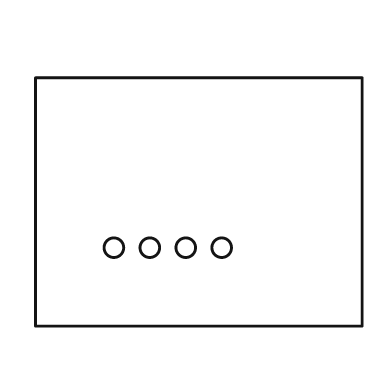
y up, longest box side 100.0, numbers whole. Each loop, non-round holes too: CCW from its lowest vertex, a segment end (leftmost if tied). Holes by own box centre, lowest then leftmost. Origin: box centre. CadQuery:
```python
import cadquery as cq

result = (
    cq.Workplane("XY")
    .moveTo(-50.0, -38.0)
    .lineTo(50.0, -38.0)
    .lineTo(50.0, 38.0)
    .lineTo(-50.0, 38.0)
    .close()
    .moveTo(-26.0, -14.0)
    .circle(3.0)
    .moveTo(-15.0, -14.0)
    .circle(3.0)
    .moveTo(-4.0, -14.0)
    .circle(3.0)
    .moveTo(7.0, -14.0)
    .circle(3.0)
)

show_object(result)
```